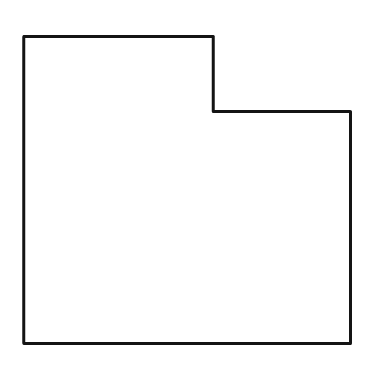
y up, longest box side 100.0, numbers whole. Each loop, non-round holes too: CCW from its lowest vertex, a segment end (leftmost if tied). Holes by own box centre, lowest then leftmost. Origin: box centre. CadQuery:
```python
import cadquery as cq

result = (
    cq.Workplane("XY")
    .moveTo(-50.0, -47.0)
    .lineTo(50.0, -47.0)
    .lineTo(50.0, 24.0)
    .lineTo(8.0, 24.0)
    .lineTo(8.0, 47.0)
    .lineTo(-50.0, 47.0)
    .close()
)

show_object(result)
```